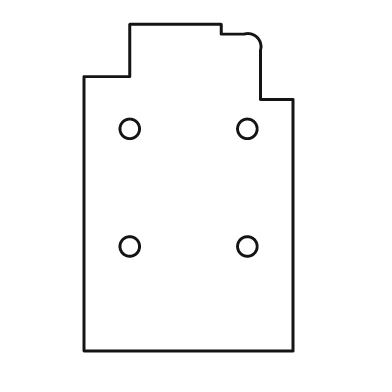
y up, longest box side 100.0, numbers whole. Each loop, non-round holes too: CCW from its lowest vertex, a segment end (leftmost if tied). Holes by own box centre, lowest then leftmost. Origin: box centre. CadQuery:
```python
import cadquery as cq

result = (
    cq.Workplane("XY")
    .moveTo(-32.0, -50.0)
    .lineTo(32.0, -50.0)
    .lineTo(32.0, 27.0)
    .lineTo(22.0, 27.0)
    .lineTo(22.0, 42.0)
    .threePointArc((21.0, 46.0), (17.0, 47.0))
    .lineTo(10.0, 47.0)
    .lineTo(10.0, 50.0)
    .lineTo(-18.0, 50.0)
    .lineTo(-18.0, 34.0)
    .lineTo(-32.0, 34.0)
    .close()
    .moveTo(-18.0, -18.0)
    .circle(3.0)
    .moveTo(18.0, -18.0)
    .circle(3.0)
    .moveTo(-18.0, 18.0)
    .circle(3.0)
    .moveTo(18.0, 18.0)
    .circle(3.0)
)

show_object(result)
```